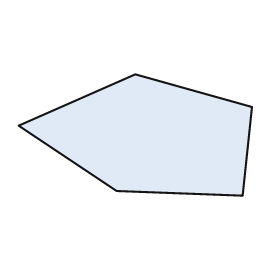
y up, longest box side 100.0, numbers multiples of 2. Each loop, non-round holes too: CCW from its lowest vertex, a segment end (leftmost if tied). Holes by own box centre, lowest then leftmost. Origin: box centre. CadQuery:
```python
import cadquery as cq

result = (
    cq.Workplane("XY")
    .moveTo(46.0, -26.0)
    .lineTo(50.0, 12.0)
    .lineTo(0.0, 26.0)
    .lineTo(-50.0, 4.0)
    .lineTo(-8.0, -24.0)
    .close()
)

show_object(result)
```